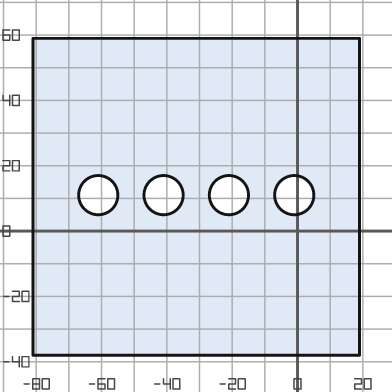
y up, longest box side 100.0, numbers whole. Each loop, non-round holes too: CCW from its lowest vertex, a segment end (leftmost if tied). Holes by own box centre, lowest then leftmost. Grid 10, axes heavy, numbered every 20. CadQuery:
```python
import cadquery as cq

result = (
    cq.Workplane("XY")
    .moveTo(-81.0, -38.0)
    .lineTo(19.0, -38.0)
    .lineTo(19.0, 59.0)
    .lineTo(-81.0, 59.0)
    .close()
    .moveTo(-61.0, 11.0)
    .circle(6.0)
    .moveTo(-41.0, 11.0)
    .circle(6.0)
    .moveTo(-21.0, 11.0)
    .circle(6.0)
    .moveTo(-1.0, 11.0)
    .circle(6.0)
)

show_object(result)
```